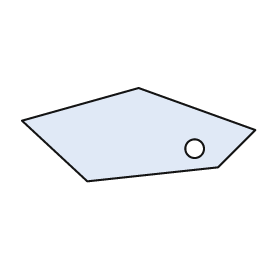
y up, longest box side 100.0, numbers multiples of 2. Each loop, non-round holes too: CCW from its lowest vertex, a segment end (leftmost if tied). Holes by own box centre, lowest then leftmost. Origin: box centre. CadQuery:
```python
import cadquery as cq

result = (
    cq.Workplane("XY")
    .moveTo(-22.0, -20.0)
    .lineTo(34.0, -14.0)
    .lineTo(50.0, 2.0)
    .lineTo(0.0, 20.0)
    .lineTo(-50.0, 6.0)
    .close()
    .moveTo(24.0, -6.0)
    .circle(4.0)
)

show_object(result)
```